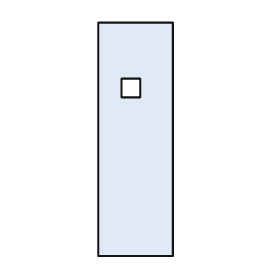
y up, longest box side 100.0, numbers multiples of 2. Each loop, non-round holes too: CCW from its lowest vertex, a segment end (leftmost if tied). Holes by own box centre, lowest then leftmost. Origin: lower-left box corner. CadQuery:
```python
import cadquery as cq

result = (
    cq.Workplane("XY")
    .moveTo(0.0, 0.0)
    .lineTo(32.0, 0.0)
    .lineTo(32.0, 100.0)
    .lineTo(0.0, 100.0)
    .close()
    .moveTo(10.0, 68.0)
    .lineTo(18.0, 68.0)
    .lineTo(18.0, 76.0)
    .lineTo(10.0, 76.0)
    .close()
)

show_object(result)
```